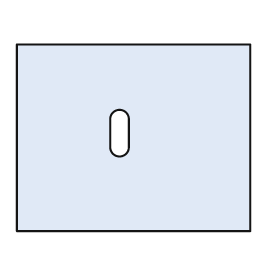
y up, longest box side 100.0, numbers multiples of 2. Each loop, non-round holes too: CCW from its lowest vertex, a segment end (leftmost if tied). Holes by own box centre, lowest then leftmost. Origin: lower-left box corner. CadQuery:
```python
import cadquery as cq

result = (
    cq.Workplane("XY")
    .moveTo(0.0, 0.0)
    .lineTo(100.0, 0.0)
    .lineTo(100.0, 80.0)
    .lineTo(0.0, 80.0)
    .close()
    .moveTo(40.0, 36.0)
    .threePointArc((44.0, 32.0), (48.0, 36.0))
    .lineTo(48.0, 48.0)
    .threePointArc((44.0, 52.0), (40.0, 48.0))
    .close()
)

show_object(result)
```